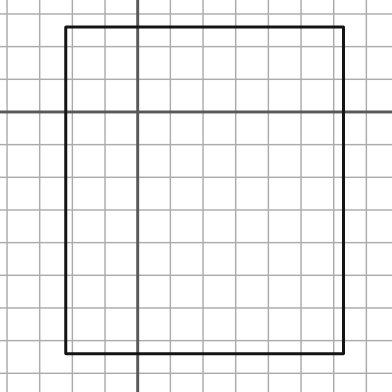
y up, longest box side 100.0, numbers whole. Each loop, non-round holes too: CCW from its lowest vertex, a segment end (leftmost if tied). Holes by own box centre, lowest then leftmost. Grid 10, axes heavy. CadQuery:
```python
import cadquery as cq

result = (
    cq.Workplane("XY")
    .moveTo(-22.0, -74.0)
    .lineTo(63.0, -74.0)
    .lineTo(63.0, 26.0)
    .lineTo(-22.0, 26.0)
    .close()
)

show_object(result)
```